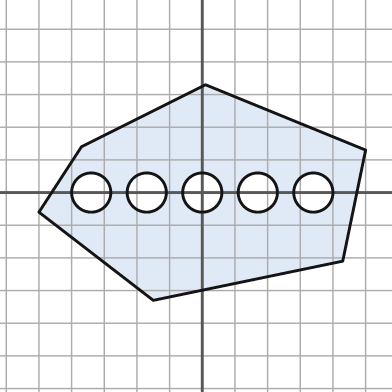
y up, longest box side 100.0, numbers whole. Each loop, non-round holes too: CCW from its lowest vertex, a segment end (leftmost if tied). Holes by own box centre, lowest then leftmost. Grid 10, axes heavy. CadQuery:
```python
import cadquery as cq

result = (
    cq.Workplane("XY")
    .moveTo(-15.0, -33.0)
    .lineTo(43.0, -21.0)
    .lineTo(50.0, 13.0)
    .lineTo(1.0, 33.0)
    .lineTo(-37.0, 14.0)
    .lineTo(-50.0, -6.0)
    .close()
    .moveTo(-34.0, 0.0)
    .circle(6.0)
    .moveTo(-17.0, 0.0)
    .circle(6.0)
    .moveTo(0.0, 0.0)
    .circle(6.0)
    .moveTo(17.0, 0.0)
    .circle(6.0)
    .moveTo(34.0, 0.0)
    .circle(6.0)
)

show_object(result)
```